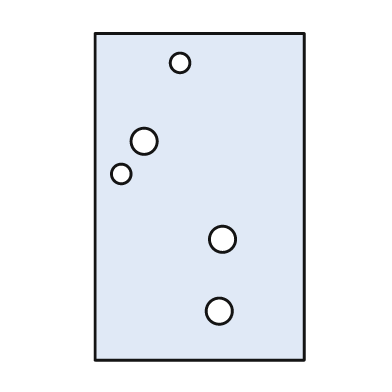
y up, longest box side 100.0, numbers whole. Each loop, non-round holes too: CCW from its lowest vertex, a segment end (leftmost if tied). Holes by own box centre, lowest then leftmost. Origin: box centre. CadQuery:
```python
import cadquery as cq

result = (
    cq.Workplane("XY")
    .moveTo(-32.0, -50.0)
    .lineTo(32.0, -50.0)
    .lineTo(32.0, 50.0)
    .lineTo(-32.0, 50.0)
    .close()
    .moveTo(6.0, -35.0)
    .circle(4.0)
    .moveTo(7.0, -13.0)
    .circle(4.0)
    .moveTo(-24.0, 7.0)
    .circle(3.0)
    .moveTo(-17.0, 17.0)
    .circle(4.0)
    .moveTo(-6.0, 41.0)
    .circle(3.0)
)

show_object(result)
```